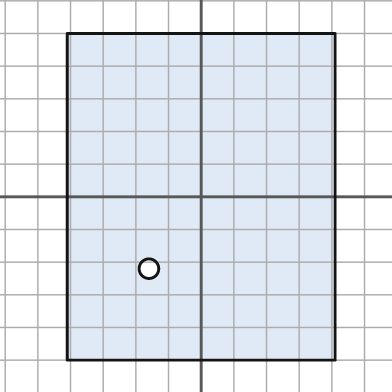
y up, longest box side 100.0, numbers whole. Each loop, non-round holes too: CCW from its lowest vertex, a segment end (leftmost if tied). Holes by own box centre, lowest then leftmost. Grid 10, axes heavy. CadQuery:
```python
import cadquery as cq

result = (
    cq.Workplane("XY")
    .moveTo(-41.0, -50.0)
    .lineTo(41.0, -50.0)
    .lineTo(41.0, 50.0)
    .lineTo(-41.0, 50.0)
    .close()
    .moveTo(-16.0, -22.0)
    .circle(3.0)
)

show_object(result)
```